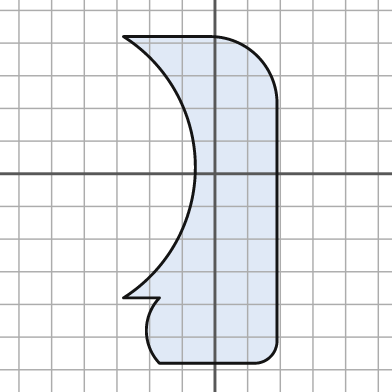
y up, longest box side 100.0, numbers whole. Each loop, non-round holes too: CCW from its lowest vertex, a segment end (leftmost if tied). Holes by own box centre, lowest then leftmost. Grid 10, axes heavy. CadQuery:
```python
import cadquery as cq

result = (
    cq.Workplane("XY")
    .moveTo(-17.0, -58.0)
    .lineTo(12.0, -58.0)
    .threePointArc((17.0, -56.0), (19.0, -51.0))
    .lineTo(19.0, 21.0)
    .threePointArc((13.0, 36.0), (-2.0, 42.0))
    .lineTo(-28.0, 42.0)
    .threePointArc((-6.0, 2.0), (-28.0, -38.0))
    .lineTo(-17.0, -38.0)
    .threePointArc((-21.0, -48.0), (-17.0, -58.0))
    .close()
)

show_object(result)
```